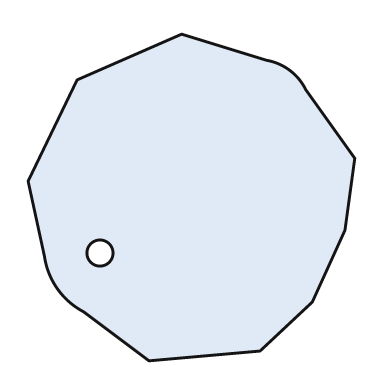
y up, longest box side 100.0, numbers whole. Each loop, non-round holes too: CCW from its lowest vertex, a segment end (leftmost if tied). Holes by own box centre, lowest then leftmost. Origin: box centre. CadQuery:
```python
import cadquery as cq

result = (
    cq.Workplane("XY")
    .moveTo(-13.0, -50.0)
    .lineTo(21.0, -47.0)
    .lineTo(37.0, -32.0)
    .lineTo(47.0, -10.0)
    .lineTo(50.0, 12.0)
    .lineTo(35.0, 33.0)
    .threePointArc((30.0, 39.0), (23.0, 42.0))
    .lineTo(-3.0, 50.0)
    .lineTo(-35.0, 36.0)
    .lineTo(-50.0, 5.0)
    .lineTo(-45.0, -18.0)
    .threePointArc((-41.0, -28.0), (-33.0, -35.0))
    .close()
    .moveTo(-28.0, -17.0)
    .circle(4.0)
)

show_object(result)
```